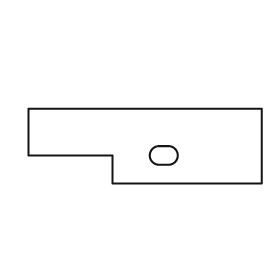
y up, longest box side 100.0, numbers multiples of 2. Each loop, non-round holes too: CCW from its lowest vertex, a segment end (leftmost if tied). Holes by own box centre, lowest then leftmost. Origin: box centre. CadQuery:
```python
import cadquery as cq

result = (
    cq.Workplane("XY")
    .moveTo(-14.0, -16.0)
    .lineTo(50.0, -16.0)
    .lineTo(50.0, 16.0)
    .lineTo(-50.0, 16.0)
    .lineTo(-50.0, -4.0)
    .lineTo(-14.0, -4.0)
    .close()
    .moveTo(6.0, -8.0)
    .lineTo(10.0, -8.0)
    .threePointArc((14.0, -4.0), (10.0, 0.0))
    .lineTo(6.0, 0.0)
    .threePointArc((2.0, -4.0), (6.0, -8.0))
    .close()
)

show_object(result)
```